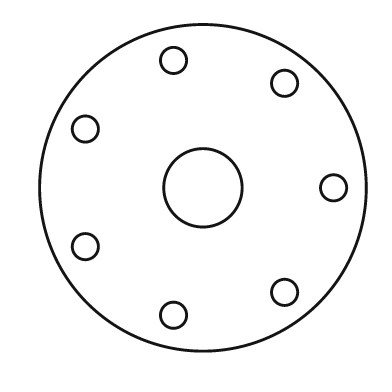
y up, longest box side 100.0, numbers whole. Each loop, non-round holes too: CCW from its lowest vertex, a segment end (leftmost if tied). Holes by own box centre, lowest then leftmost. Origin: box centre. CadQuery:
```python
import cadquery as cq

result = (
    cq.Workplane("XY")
    .moveTo(0.0, 0.0)
    .circle(50.0)
    .moveTo(-9.0, -39.0)
    .circle(4.0)
    .moveTo(25.0, -32.0)
    .circle(4.0)
    .moveTo(-36.0, -18.0)
    .circle(4.0)
    .moveTo(0.0, 0.0)
    .circle(12.0)
    .moveTo(40.0, 0.0)
    .circle(4.0)
    .moveTo(-36.0, 18.0)
    .circle(4.0)
    .moveTo(25.0, 32.0)
    .circle(4.0)
    .moveTo(-9.0, 39.0)
    .circle(4.0)
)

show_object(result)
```